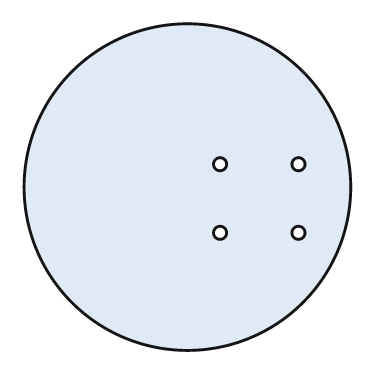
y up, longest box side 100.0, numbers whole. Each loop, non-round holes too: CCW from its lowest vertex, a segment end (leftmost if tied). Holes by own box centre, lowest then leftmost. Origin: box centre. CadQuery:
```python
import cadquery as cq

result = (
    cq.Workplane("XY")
    .moveTo(0.0, 0.0)
    .circle(50.0)
    .moveTo(10.0, -14.0)
    .circle(2.0)
    .moveTo(34.0, -14.0)
    .circle(2.0)
    .moveTo(10.0, 7.0)
    .circle(2.0)
    .moveTo(34.0, 7.0)
    .circle(2.0)
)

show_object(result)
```